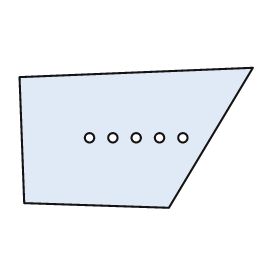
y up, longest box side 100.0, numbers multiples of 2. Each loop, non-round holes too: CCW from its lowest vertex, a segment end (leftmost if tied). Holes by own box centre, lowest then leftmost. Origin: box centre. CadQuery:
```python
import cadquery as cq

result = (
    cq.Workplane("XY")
    .moveTo(14.0, -30.0)
    .lineTo(50.0, 30.0)
    .lineTo(-50.0, 26.0)
    .lineTo(-48.0, -28.0)
    .close()
    .moveTo(-20.0, 0.0)
    .circle(2.0)
    .moveTo(-10.0, 0.0)
    .circle(2.0)
    .moveTo(0.0, 0.0)
    .circle(2.0)
    .moveTo(10.0, 0.0)
    .circle(2.0)
    .moveTo(20.0, 0.0)
    .circle(2.0)
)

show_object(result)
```